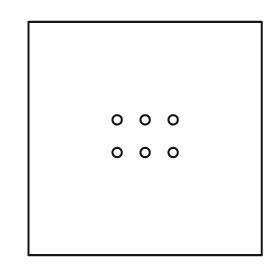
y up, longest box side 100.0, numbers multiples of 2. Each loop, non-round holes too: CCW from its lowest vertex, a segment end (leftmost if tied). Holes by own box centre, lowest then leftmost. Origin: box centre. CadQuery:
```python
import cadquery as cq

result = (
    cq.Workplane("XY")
    .moveTo(-50.0, -50.0)
    .lineTo(50.0, -50.0)
    .lineTo(50.0, 50.0)
    .lineTo(-50.0, 50.0)
    .close()
    .moveTo(-12.0, -6.0)
    .circle(2.0)
    .moveTo(0.0, -6.0)
    .circle(2.0)
    .moveTo(12.0, -6.0)
    .circle(2.0)
    .moveTo(-12.0, 8.0)
    .circle(2.0)
    .moveTo(0.0, 8.0)
    .circle(2.0)
    .moveTo(12.0, 8.0)
    .circle(2.0)
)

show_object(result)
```